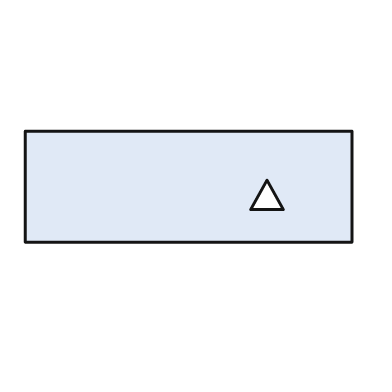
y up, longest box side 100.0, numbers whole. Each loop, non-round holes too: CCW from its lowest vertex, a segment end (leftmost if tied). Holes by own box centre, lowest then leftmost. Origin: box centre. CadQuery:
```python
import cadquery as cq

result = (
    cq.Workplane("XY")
    .moveTo(-50.0, -17.0)
    .lineTo(50.0, -17.0)
    .lineTo(50.0, 17.0)
    .lineTo(-50.0, 17.0)
    .close()
    .moveTo(19.0, -7.0)
    .lineTo(29.0, -7.0)
    .lineTo(24.0, 2.0)
    .close()
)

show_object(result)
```